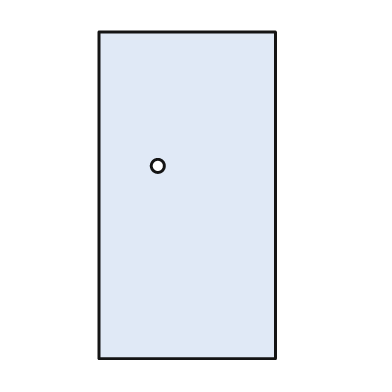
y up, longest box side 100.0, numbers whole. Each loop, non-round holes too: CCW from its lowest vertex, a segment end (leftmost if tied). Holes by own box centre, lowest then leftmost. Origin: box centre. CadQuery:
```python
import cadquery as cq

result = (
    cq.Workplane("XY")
    .moveTo(-27.0, -50.0)
    .lineTo(27.0, -50.0)
    .lineTo(27.0, 50.0)
    .lineTo(-27.0, 50.0)
    .close()
    .moveTo(-9.0, 9.0)
    .circle(2.0)
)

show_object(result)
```